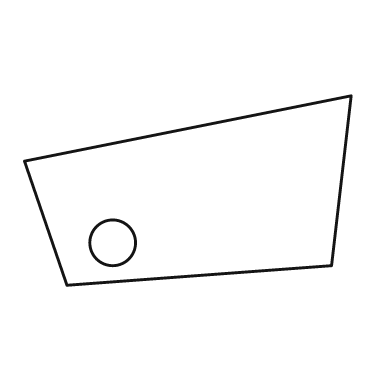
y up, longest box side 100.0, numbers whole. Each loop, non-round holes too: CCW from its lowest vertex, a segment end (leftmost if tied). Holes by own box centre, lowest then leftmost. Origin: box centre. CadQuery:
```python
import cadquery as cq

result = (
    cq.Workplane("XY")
    .moveTo(-37.0, -29.0)
    .lineTo(44.0, -23.0)
    .lineTo(50.0, 29.0)
    .lineTo(-50.0, 9.0)
    .close()
    .moveTo(-23.0, -16.0)
    .circle(7.0)
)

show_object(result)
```